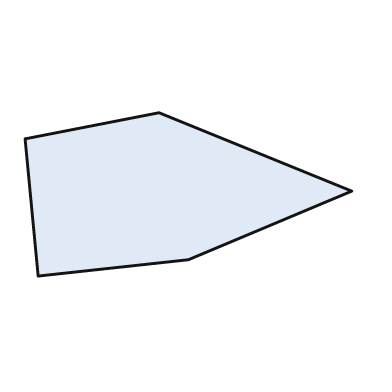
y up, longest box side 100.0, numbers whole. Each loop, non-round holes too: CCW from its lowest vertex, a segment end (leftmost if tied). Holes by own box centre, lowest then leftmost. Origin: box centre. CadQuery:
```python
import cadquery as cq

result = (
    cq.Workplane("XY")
    .moveTo(-46.0, -25.0)
    .lineTo(0.0, -20.0)
    .lineTo(50.0, 1.0)
    .lineTo(-9.0, 25.0)
    .lineTo(-50.0, 17.0)
    .close()
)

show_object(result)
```